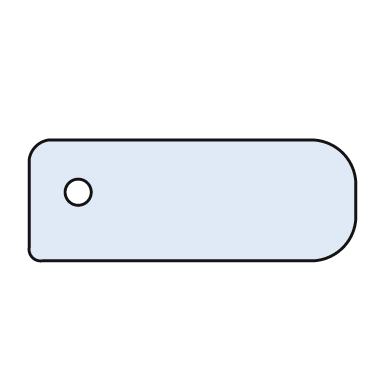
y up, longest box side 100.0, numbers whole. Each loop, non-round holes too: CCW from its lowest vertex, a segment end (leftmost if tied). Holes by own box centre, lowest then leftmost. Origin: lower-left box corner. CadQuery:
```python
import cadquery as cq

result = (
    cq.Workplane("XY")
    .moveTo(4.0, 0.0)
    .lineTo(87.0, 0.0)
    .threePointArc((96.0, 4.0), (100.0, 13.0))
    .lineTo(100.0, 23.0)
    .threePointArc((96.0, 33.0), (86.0, 37.0))
    .lineTo(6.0, 37.0)
    .threePointArc((2.0, 35.0), (0.0, 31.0))
    .lineTo(0.0, 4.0)
    .threePointArc((1.0, 1.0), (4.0, 0.0))
    .close()
    .moveTo(15.0, 21.0)
    .circle(4.0)
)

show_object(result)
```